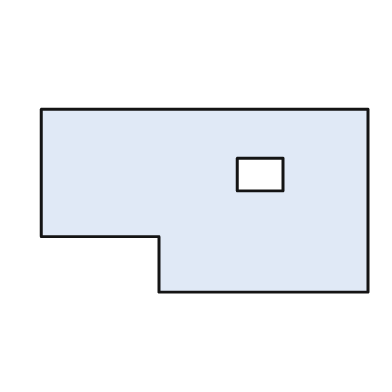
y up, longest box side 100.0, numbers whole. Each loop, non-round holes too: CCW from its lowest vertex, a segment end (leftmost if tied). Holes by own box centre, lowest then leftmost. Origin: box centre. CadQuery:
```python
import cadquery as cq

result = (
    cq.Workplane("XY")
    .moveTo(-14.0, -28.0)
    .lineTo(50.0, -28.0)
    .lineTo(50.0, 28.0)
    .lineTo(-50.0, 28.0)
    .lineTo(-50.0, -11.0)
    .lineTo(-14.0, -11.0)
    .close()
    .moveTo(10.0, 3.0)
    .lineTo(24.0, 3.0)
    .lineTo(24.0, 13.0)
    .lineTo(10.0, 13.0)
    .close()
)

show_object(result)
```